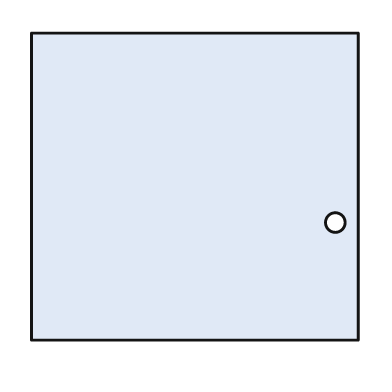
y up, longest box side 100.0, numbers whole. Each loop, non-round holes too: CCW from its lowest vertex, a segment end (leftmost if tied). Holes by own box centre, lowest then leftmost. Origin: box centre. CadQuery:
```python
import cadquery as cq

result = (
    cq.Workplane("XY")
    .moveTo(-50.0, -47.0)
    .lineTo(50.0, -47.0)
    .lineTo(50.0, 47.0)
    .lineTo(-50.0, 47.0)
    .close()
    .moveTo(43.0, -11.0)
    .circle(3.0)
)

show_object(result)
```